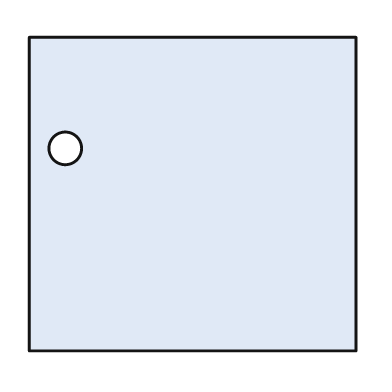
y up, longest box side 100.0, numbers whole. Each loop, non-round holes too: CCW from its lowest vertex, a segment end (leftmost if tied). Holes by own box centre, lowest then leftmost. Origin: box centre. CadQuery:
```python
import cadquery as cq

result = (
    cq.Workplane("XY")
    .moveTo(-50.0, -48.0)
    .lineTo(50.0, -48.0)
    .lineTo(50.0, 48.0)
    .lineTo(-50.0, 48.0)
    .close()
    .moveTo(-39.0, 14.0)
    .circle(5.0)
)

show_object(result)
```